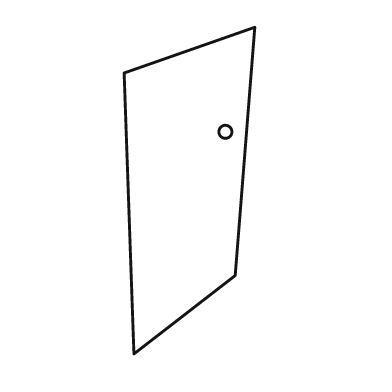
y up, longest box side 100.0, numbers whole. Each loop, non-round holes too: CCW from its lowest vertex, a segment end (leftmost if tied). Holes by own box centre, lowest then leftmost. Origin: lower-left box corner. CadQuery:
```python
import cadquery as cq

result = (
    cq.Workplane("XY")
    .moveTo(3.0, 0.0)
    .lineTo(34.0, 24.0)
    .lineTo(40.0, 100.0)
    .lineTo(0.0, 86.0)
    .close()
    .moveTo(31.0, 68.0)
    .circle(2.0)
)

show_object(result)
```